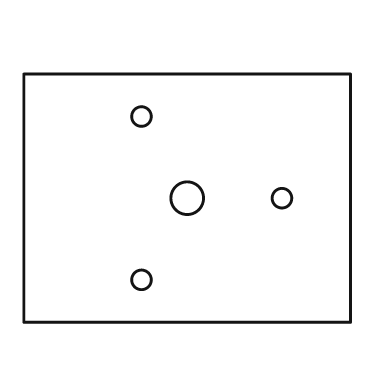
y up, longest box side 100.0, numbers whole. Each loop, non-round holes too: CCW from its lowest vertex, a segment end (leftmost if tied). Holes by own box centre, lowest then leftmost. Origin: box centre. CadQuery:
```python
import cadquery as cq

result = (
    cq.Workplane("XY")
    .moveTo(-50.0, -38.0)
    .lineTo(50.0, -38.0)
    .lineTo(50.0, 38.0)
    .lineTo(-50.0, 38.0)
    .close()
    .moveTo(-14.0, -25.0)
    .circle(3.0)
    .moveTo(0.0, 0.0)
    .circle(5.0)
    .moveTo(29.0, 0.0)
    .circle(3.0)
    .moveTo(-14.0, 25.0)
    .circle(3.0)
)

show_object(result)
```